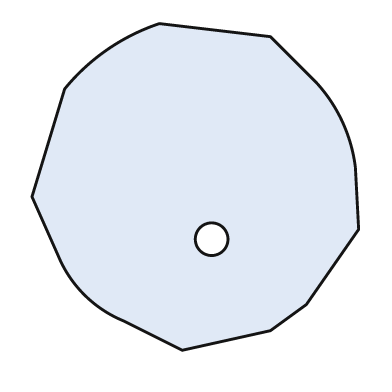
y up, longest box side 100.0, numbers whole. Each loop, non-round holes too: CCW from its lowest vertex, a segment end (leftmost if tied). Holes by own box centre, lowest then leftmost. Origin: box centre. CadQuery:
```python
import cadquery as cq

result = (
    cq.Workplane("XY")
    .moveTo(-4.0, -50.0)
    .lineTo(23.0, -44.0)
    .lineTo(34.0, -36.0)
    .lineTo(50.0, -13.0)
    .lineTo(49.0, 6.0)
    .threePointArc((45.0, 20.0), (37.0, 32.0))
    .lineTo(23.0, 46.0)
    .lineTo(-11.0, 50.0)
    .threePointArc((-27.0, 42.0), (-40.0, 30.0))
    .lineTo(-50.0, -3.0)
    .lineTo(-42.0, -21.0)
    .threePointArc((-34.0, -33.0), (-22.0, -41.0))
    .close()
    .moveTo(5.0, -16.0)
    .circle(5.0)
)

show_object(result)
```